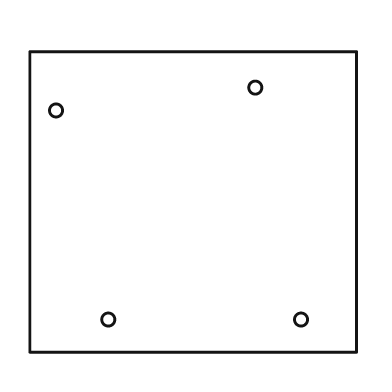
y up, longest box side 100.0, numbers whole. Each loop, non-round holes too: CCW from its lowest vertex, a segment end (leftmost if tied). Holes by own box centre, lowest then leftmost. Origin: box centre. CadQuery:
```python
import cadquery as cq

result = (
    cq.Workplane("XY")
    .moveTo(-50.0, -46.0)
    .lineTo(50.0, -46.0)
    .lineTo(50.0, 46.0)
    .lineTo(-50.0, 46.0)
    .close()
    .moveTo(-26.0, -36.0)
    .circle(2.0)
    .moveTo(33.0, -36.0)
    .circle(2.0)
    .moveTo(-42.0, 28.0)
    .circle(2.0)
    .moveTo(19.0, 35.0)
    .circle(2.0)
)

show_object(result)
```